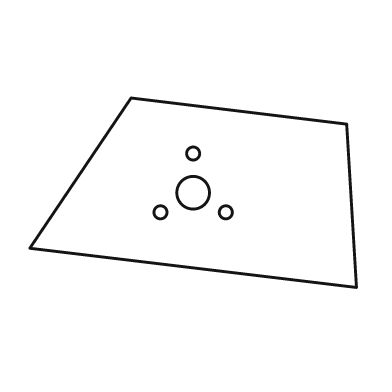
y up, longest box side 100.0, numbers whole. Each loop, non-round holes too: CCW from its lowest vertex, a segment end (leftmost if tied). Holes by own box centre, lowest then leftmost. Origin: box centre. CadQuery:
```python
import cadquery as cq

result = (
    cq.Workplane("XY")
    .moveTo(50.0, -29.0)
    .lineTo(47.0, 21.0)
    .lineTo(-19.0, 29.0)
    .lineTo(-50.0, -17.0)
    .close()
    .moveTo(-10.0, -6.0)
    .circle(2.0)
    .moveTo(10.0, -6.0)
    .circle(2.0)
    .moveTo(0.0, 0.0)
    .circle(5.0)
    .moveTo(0.0, 12.0)
    .circle(2.0)
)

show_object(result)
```